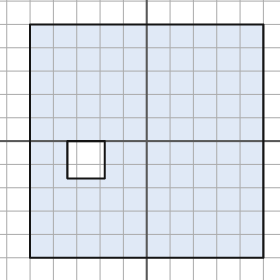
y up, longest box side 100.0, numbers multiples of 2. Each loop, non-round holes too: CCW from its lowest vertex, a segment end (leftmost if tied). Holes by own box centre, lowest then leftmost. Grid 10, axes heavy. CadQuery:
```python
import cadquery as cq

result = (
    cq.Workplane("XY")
    .moveTo(-50.0, -50.0)
    .lineTo(50.0, -50.0)
    .lineTo(50.0, 50.0)
    .lineTo(-50.0, 50.0)
    .close()
    .moveTo(-34.0, -16.0)
    .lineTo(-18.0, -16.0)
    .lineTo(-18.0, 0.0)
    .lineTo(-34.0, 0.0)
    .close()
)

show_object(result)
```